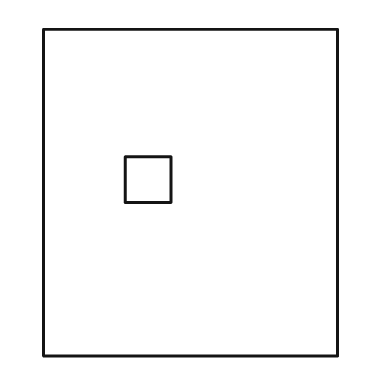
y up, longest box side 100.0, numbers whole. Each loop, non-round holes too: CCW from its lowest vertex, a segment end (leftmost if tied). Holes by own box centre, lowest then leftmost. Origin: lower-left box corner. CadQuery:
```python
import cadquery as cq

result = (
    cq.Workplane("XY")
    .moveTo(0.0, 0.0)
    .lineTo(90.0, 0.0)
    .lineTo(90.0, 100.0)
    .lineTo(0.0, 100.0)
    .close()
    .moveTo(25.0, 47.0)
    .lineTo(39.0, 47.0)
    .lineTo(39.0, 61.0)
    .lineTo(25.0, 61.0)
    .close()
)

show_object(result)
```